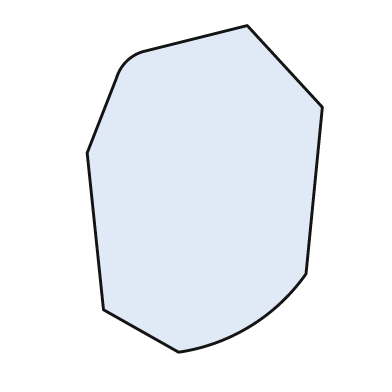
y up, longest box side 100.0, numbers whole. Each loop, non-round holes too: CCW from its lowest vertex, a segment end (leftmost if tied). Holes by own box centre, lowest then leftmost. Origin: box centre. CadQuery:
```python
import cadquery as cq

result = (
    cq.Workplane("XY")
    .moveTo(-8.0, -50.0)
    .threePointArc((14.0, -42.0), (31.0, -26.0))
    .lineTo(36.0, 25.0)
    .lineTo(13.0, 50.0)
    .lineTo(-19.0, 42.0)
    .threePointArc((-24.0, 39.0), (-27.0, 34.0))
    .lineTo(-36.0, 11.0)
    .lineTo(-31.0, -37.0)
    .close()
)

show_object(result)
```